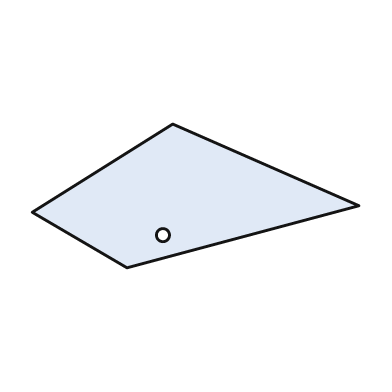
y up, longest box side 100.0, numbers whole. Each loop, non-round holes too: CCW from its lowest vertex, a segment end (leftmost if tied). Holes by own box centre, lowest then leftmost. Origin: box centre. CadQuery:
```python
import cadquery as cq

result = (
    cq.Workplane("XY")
    .moveTo(-21.0, -22.0)
    .lineTo(50.0, -3.0)
    .lineTo(-7.0, 22.0)
    .lineTo(-50.0, -5.0)
    .close()
    .moveTo(-10.0, -12.0)
    .circle(2.0)
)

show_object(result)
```